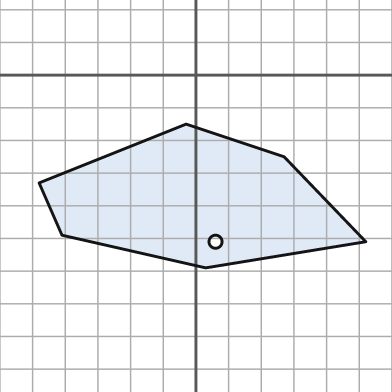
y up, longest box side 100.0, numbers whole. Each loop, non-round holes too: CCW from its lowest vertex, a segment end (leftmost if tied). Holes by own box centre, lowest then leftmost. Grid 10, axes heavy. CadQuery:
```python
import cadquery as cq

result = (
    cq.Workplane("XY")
    .moveTo(3.0, -59.0)
    .lineTo(52.0, -51.0)
    .lineTo(27.0, -25.0)
    .lineTo(-3.0, -15.0)
    .lineTo(-48.0, -33.0)
    .lineTo(-41.0, -49.0)
    .close()
    .moveTo(6.0, -51.0)
    .circle(2.0)
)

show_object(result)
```